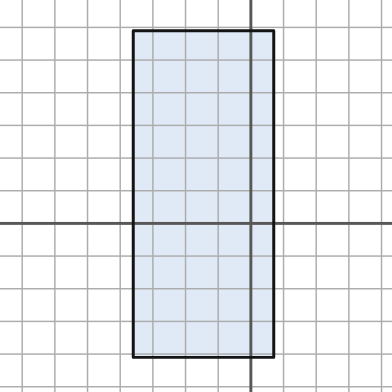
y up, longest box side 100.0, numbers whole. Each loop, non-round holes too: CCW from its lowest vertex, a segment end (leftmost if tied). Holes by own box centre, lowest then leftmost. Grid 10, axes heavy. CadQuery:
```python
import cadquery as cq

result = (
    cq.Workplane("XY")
    .moveTo(-36.0, -41.0)
    .lineTo(7.0, -41.0)
    .lineTo(7.0, 59.0)
    .lineTo(-36.0, 59.0)
    .close()
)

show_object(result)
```